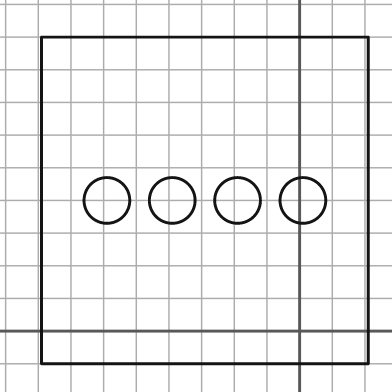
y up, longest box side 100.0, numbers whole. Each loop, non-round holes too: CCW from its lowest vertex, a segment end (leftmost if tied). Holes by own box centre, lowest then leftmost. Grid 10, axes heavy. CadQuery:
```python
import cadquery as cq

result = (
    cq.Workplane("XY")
    .moveTo(-79.0, -10.0)
    .lineTo(21.0, -10.0)
    .lineTo(21.0, 90.0)
    .lineTo(-79.0, 90.0)
    .close()
    .moveTo(-59.0, 40.0)
    .circle(7.0)
    .moveTo(-39.0, 40.0)
    .circle(7.0)
    .moveTo(-19.0, 40.0)
    .circle(7.0)
    .moveTo(1.0, 40.0)
    .circle(7.0)
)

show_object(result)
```